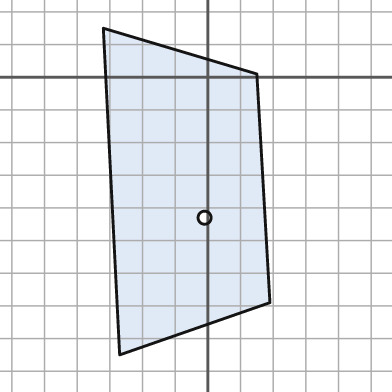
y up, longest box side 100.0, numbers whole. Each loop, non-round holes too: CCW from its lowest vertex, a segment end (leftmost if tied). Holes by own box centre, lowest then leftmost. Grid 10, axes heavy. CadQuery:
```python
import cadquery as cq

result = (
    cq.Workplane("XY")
    .moveTo(-27.0, -85.0)
    .lineTo(19.0, -69.0)
    .lineTo(15.0, 1.0)
    .lineTo(-32.0, 15.0)
    .close()
    .moveTo(-1.0, -43.0)
    .circle(2.0)
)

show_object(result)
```